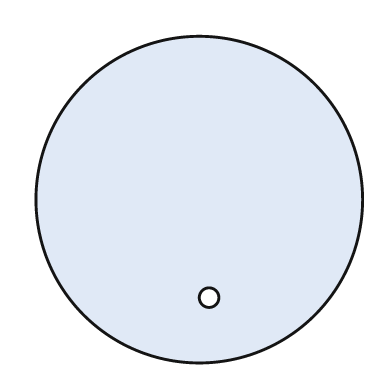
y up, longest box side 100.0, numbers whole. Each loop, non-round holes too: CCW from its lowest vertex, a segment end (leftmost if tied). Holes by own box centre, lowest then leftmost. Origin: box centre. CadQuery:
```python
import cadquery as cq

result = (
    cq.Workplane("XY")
    .moveTo(0.0, 0.0)
    .circle(50.0)
    .moveTo(3.0, -30.0)
    .circle(3.0)
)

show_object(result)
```